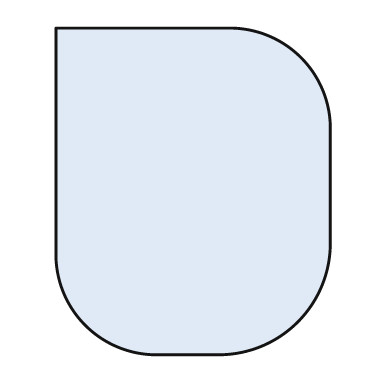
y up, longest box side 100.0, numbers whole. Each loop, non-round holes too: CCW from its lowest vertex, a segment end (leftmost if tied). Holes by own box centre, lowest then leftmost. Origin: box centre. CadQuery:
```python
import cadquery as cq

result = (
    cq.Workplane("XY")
    .moveTo(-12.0, -50.0)
    .lineTo(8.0, -50.0)
    .threePointArc((32.0, -40.0), (42.0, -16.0))
    .lineTo(42.0, 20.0)
    .threePointArc((33.0, 41.0), (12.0, 50.0))
    .lineTo(-42.0, 50.0)
    .lineTo(-42.0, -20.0)
    .threePointArc((-33.0, -41.0), (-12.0, -50.0))
    .close()
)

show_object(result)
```